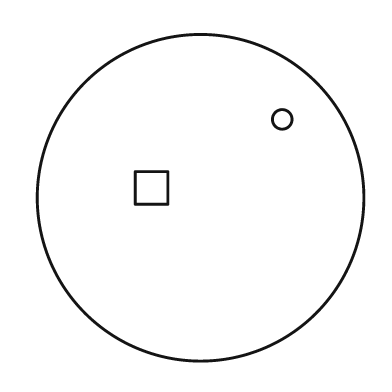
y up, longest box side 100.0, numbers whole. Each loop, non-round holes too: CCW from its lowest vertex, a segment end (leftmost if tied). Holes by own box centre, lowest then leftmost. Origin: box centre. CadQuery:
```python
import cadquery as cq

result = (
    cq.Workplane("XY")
    .moveTo(0.0, 0.0)
    .circle(50.0)
    .moveTo(-20.0, -2.0)
    .lineTo(-10.0, -2.0)
    .lineTo(-10.0, 8.0)
    .lineTo(-20.0, 8.0)
    .close()
    .moveTo(25.0, 24.0)
    .circle(3.0)
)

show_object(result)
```